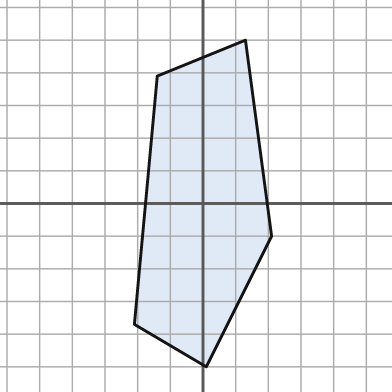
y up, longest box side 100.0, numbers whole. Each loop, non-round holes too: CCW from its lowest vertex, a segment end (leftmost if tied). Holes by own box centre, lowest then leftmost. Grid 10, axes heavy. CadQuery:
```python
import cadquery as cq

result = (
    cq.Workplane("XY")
    .moveTo(1.0, -50.0)
    .lineTo(21.0, -10.0)
    .lineTo(13.0, 50.0)
    .lineTo(-14.0, 39.0)
    .lineTo(-21.0, -37.0)
    .close()
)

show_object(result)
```